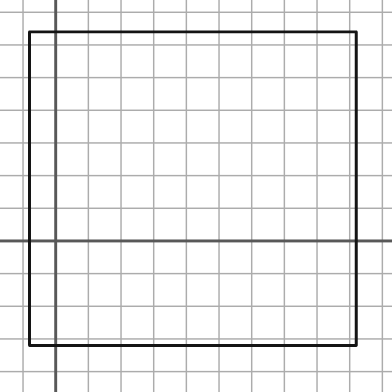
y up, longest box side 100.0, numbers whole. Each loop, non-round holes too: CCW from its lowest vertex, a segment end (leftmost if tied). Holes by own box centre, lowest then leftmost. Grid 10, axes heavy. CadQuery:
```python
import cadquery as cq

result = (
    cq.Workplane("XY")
    .moveTo(-8.0, -32.0)
    .lineTo(92.0, -32.0)
    .lineTo(92.0, 64.0)
    .lineTo(-8.0, 64.0)
    .close()
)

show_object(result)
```